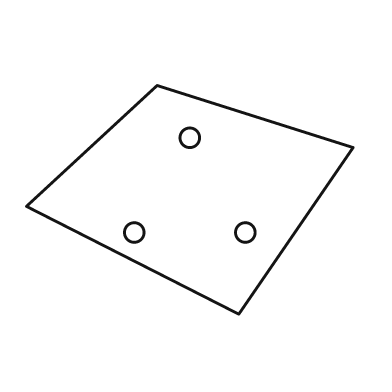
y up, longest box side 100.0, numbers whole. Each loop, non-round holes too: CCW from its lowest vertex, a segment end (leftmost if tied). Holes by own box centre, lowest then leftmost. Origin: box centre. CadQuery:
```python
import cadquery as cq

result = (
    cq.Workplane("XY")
    .moveTo(15.0, -35.0)
    .lineTo(50.0, 16.0)
    .lineTo(-10.0, 35.0)
    .lineTo(-50.0, -2.0)
    .close()
    .moveTo(-17.0, -10.0)
    .circle(3.0)
    .moveTo(17.0, -10.0)
    .circle(3.0)
    .moveTo(0.0, 19.0)
    .circle(3.0)
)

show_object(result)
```